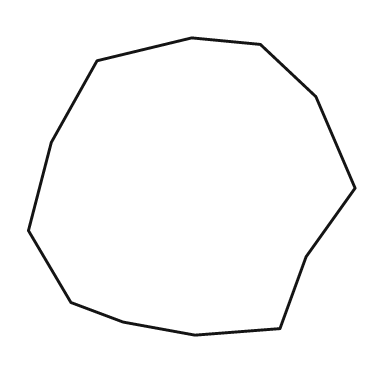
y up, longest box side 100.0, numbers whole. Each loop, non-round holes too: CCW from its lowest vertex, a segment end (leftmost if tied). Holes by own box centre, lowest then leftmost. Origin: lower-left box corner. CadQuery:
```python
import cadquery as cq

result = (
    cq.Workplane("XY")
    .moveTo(51.0, 0.0)
    .lineTo(77.0, 2.0)
    .lineTo(85.0, 24.0)
    .lineTo(100.0, 45.0)
    .lineTo(88.0, 73.0)
    .lineTo(71.0, 89.0)
    .lineTo(50.0, 91.0)
    .lineTo(21.0, 84.0)
    .lineTo(7.0, 59.0)
    .lineTo(0.0, 32.0)
    .lineTo(13.0, 10.0)
    .lineTo(29.0, 4.0)
    .close()
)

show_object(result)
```